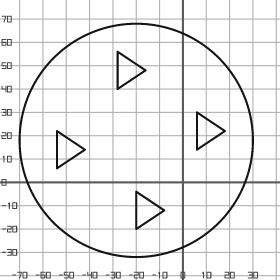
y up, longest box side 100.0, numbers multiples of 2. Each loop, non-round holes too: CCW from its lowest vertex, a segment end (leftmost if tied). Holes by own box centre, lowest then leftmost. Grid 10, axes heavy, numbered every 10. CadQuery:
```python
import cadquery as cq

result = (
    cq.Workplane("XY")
    .moveTo(-20.0, 18.0)
    .circle(50.0)
    .moveTo(-20.0, -20.0)
    .lineTo(-8.0, -12.0)
    .lineTo(-20.0, -4.0)
    .close()
    .moveTo(-54.0, 6.0)
    .lineTo(-42.0, 14.0)
    .lineTo(-54.0, 22.0)
    .close()
    .moveTo(6.0, 14.0)
    .lineTo(18.0, 22.0)
    .lineTo(6.0, 30.0)
    .close()
    .moveTo(-28.0, 40.0)
    .lineTo(-16.0, 48.0)
    .lineTo(-28.0, 56.0)
    .close()
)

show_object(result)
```